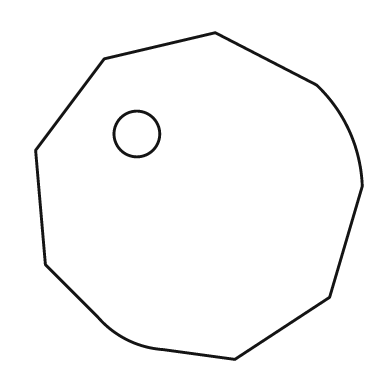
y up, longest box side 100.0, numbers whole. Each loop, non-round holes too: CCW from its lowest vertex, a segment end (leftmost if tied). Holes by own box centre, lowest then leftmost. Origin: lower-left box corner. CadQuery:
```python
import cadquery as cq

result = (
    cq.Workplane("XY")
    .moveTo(61.0, 0.0)
    .lineTo(90.0, 19.0)
    .lineTo(100.0, 53.0)
    .threePointArc((96.0, 70.0), (86.0, 84.0))
    .lineTo(55.0, 100.0)
    .lineTo(21.0, 92.0)
    .lineTo(0.0, 64.0)
    .lineTo(3.0, 29.0)
    .lineTo(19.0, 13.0)
    .threePointArc((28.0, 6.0), (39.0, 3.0))
    .close()
    .moveTo(31.0, 69.0)
    .circle(7.0)
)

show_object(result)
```